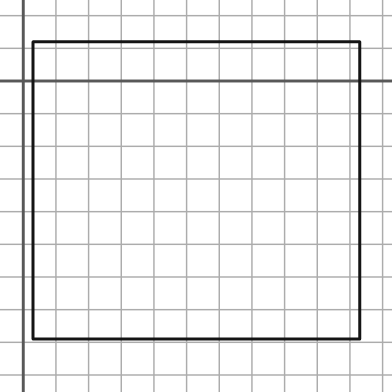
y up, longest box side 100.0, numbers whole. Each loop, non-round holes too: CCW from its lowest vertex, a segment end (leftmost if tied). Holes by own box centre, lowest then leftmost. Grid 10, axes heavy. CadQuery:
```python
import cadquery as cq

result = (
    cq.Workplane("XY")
    .moveTo(3.0, -79.0)
    .lineTo(103.0, -79.0)
    .lineTo(103.0, 12.0)
    .lineTo(3.0, 12.0)
    .close()
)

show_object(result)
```